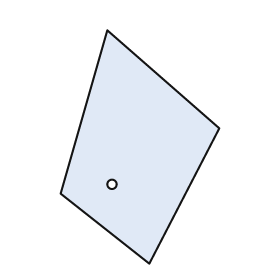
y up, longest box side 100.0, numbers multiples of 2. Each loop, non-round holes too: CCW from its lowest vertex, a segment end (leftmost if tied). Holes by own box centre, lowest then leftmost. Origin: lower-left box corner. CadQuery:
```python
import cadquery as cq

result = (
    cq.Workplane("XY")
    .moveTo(38.0, 0.0)
    .lineTo(68.0, 58.0)
    .lineTo(20.0, 100.0)
    .lineTo(0.0, 30.0)
    .close()
    .moveTo(22.0, 34.0)
    .circle(2.0)
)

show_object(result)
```